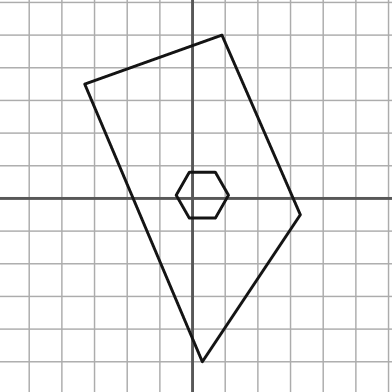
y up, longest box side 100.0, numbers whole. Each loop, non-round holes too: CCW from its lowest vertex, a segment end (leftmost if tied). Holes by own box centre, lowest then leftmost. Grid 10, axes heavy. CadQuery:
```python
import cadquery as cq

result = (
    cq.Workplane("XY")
    .moveTo(3.0, -50.0)
    .lineTo(33.0, -5.0)
    .lineTo(9.0, 50.0)
    .lineTo(-33.0, 35.0)
    .close()
    .moveTo(-1.0, -6.0)
    .lineTo(7.0, -6.0)
    .lineTo(11.0, 1.0)
    .lineTo(7.0, 8.0)
    .lineTo(-1.0, 8.0)
    .lineTo(-5.0, 1.0)
    .close()
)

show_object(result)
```